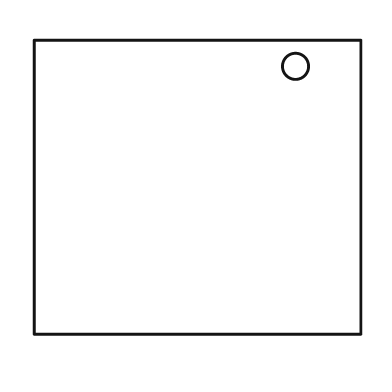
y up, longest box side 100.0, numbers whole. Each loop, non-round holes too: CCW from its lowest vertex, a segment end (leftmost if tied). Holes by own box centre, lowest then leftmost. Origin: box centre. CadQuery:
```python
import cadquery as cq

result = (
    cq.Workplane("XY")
    .moveTo(-50.0, -45.0)
    .lineTo(50.0, -45.0)
    .lineTo(50.0, 45.0)
    .lineTo(-50.0, 45.0)
    .close()
    .moveTo(30.0, 37.0)
    .circle(4.0)
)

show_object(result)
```